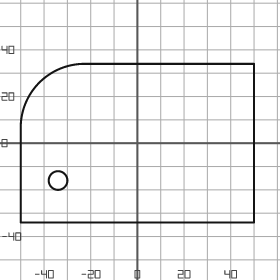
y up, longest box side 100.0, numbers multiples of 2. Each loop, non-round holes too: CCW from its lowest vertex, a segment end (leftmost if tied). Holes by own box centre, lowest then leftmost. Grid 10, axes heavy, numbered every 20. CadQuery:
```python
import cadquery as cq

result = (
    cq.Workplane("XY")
    .moveTo(-50.0, -34.0)
    .lineTo(50.0, -34.0)
    .lineTo(50.0, 34.0)
    .lineTo(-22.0, 34.0)
    .threePointArc((-42.0, 26.0), (-50.0, 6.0))
    .close()
    .moveTo(-34.0, -16.0)
    .circle(4.0)
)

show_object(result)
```